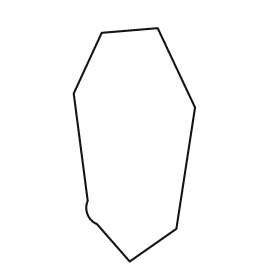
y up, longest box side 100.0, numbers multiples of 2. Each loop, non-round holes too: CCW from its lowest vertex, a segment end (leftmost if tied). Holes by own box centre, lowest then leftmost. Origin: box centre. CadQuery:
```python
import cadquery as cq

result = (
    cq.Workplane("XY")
    .moveTo(-2.0, -50.0)
    .lineTo(18.0, -36.0)
    .lineTo(26.0, 16.0)
    .lineTo(10.0, 50.0)
    .lineTo(-14.0, 48.0)
    .lineTo(-26.0, 22.0)
    .lineTo(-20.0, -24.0)
    .threePointArc((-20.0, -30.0), (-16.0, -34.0))
    .close()
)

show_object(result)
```